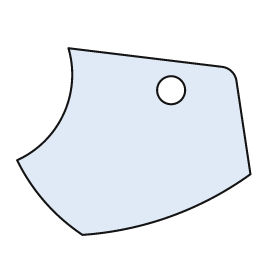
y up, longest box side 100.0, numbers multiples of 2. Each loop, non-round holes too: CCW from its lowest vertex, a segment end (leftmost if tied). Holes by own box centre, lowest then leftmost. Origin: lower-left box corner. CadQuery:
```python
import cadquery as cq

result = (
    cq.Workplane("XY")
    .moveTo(28.0, 0.0)
    .threePointArc((66.0, 8.0), (100.0, 26.0))
    .lineTo(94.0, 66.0)
    .threePointArc((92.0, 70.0), (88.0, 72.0))
    .lineTo(22.0, 80.0)
    .threePointArc((20.0, 52.0), (0.0, 32.0))
    .threePointArc((12.0, 14.0), (28.0, 0.0))
    .close()
    .moveTo(66.0, 62.0)
    .circle(6.0)
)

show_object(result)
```